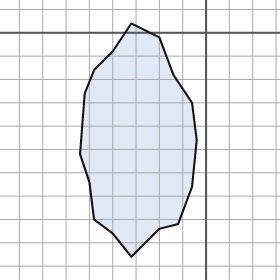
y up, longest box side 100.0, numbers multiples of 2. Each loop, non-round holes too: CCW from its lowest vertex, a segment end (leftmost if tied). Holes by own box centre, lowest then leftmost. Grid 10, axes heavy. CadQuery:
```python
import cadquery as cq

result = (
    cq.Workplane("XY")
    .moveTo(-32.0, -96.0)
    .lineTo(-20.0, -84.0)
    .lineTo(-12.0, -82.0)
    .lineTo(-6.0, -66.0)
    .lineTo(-4.0, -46.0)
    .lineTo(-6.0, -30.0)
    .lineTo(-14.0, -18.0)
    .lineTo(-20.0, -2.0)
    .lineTo(-32.0, 4.0)
    .lineTo(-40.0, -8.0)
    .lineTo(-48.0, -16.0)
    .lineTo(-52.0, -26.0)
    .lineTo(-54.0, -52.0)
    .lineTo(-50.0, -64.0)
    .lineTo(-48.0, -80.0)
    .lineTo(-40.0, -86.0)
    .close()
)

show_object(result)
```